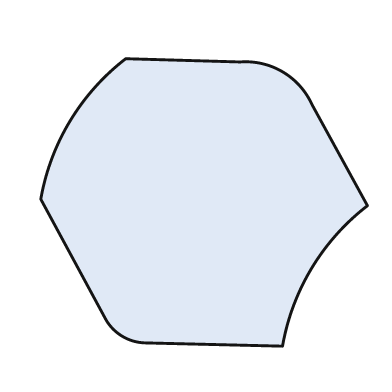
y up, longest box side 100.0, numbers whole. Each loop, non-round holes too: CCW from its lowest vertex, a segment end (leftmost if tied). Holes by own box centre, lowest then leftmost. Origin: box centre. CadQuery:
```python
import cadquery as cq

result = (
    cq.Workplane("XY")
    .moveTo(24.0, -44.0)
    .threePointArc((33.0, -20.0), (50.0, -1.0))
    .lineTo(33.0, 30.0)
    .threePointArc((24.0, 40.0), (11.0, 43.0))
    .lineTo(-24.0, 44.0)
    .threePointArc((-41.0, 25.0), (-50.0, 1.0))
    .lineTo(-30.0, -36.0)
    .threePointArc((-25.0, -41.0), (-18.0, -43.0))
    .close()
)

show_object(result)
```